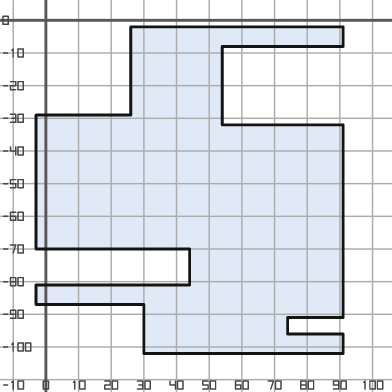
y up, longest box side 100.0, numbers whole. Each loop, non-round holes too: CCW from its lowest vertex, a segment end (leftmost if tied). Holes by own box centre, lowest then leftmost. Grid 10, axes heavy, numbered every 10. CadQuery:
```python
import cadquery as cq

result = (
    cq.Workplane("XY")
    .moveTo(30.0, -102.0)
    .lineTo(91.0, -102.0)
    .lineTo(91.0, -96.0)
    .lineTo(74.0, -96.0)
    .lineTo(74.0, -91.0)
    .lineTo(91.0, -91.0)
    .lineTo(91.0, -32.0)
    .lineTo(54.0, -32.0)
    .lineTo(54.0, -8.0)
    .lineTo(91.0, -8.0)
    .lineTo(91.0, -2.0)
    .lineTo(26.0, -2.0)
    .lineTo(26.0, -29.0)
    .lineTo(-3.0, -29.0)
    .lineTo(-3.0, -70.0)
    .lineTo(44.0, -70.0)
    .lineTo(44.0, -81.0)
    .lineTo(-3.0, -81.0)
    .lineTo(-3.0, -87.0)
    .lineTo(30.0, -87.0)
    .close()
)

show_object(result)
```